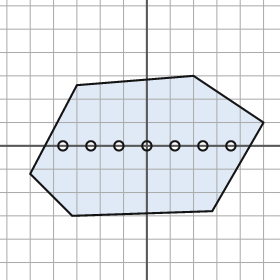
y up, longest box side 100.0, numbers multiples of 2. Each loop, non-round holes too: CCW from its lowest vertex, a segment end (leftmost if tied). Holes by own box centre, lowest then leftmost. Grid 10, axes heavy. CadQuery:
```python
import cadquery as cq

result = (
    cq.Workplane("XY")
    .moveTo(-32.0, -30.0)
    .lineTo(28.0, -28.0)
    .lineTo(50.0, 10.0)
    .lineTo(20.0, 30.0)
    .lineTo(-30.0, 26.0)
    .lineTo(-50.0, -12.0)
    .close()
    .moveTo(-36.0, 0.0)
    .circle(2.0)
    .moveTo(-24.0, 0.0)
    .circle(2.0)
    .moveTo(-12.0, 0.0)
    .circle(2.0)
    .moveTo(0.0, 0.0)
    .circle(2.0)
    .moveTo(12.0, 0.0)
    .circle(2.0)
    .moveTo(24.0, 0.0)
    .circle(2.0)
    .moveTo(36.0, 0.0)
    .circle(2.0)
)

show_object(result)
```